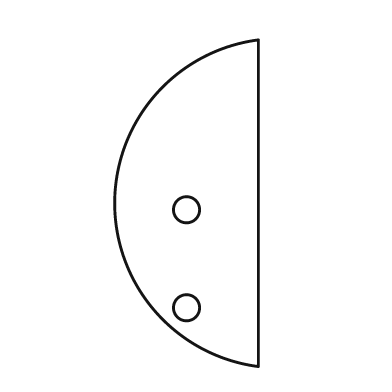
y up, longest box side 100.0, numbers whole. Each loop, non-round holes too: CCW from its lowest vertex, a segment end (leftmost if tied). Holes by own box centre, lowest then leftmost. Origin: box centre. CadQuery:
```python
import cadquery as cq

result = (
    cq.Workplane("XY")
    .moveTo(22.0, -50.0)
    .lineTo(22.0, 50.0)
    .threePointArc((-22.0, 0.0), (22.0, -50.0))
    .close()
    .moveTo(0.0, -32.0)
    .circle(4.0)
    .moveTo(0.0, -2.0)
    .circle(4.0)
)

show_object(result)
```